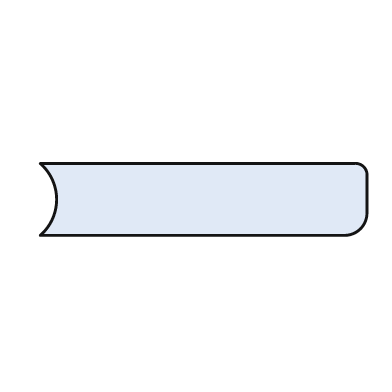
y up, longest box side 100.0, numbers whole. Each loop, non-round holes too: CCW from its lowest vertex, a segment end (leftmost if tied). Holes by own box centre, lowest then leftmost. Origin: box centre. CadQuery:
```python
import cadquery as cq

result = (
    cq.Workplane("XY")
    .moveTo(-50.0, -11.0)
    .lineTo(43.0, -11.0)
    .threePointArc((48.0, -9.0), (50.0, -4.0))
    .lineTo(50.0, 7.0)
    .threePointArc((49.0, 10.0), (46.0, 11.0))
    .lineTo(-50.0, 11.0)
    .threePointArc((-45.0, 0.0), (-50.0, -11.0))
    .close()
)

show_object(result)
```